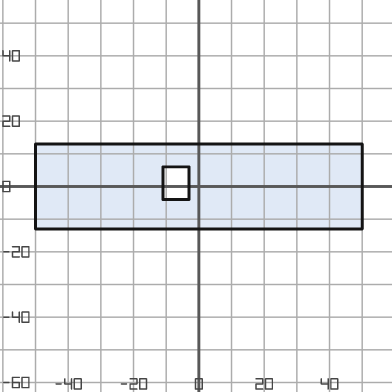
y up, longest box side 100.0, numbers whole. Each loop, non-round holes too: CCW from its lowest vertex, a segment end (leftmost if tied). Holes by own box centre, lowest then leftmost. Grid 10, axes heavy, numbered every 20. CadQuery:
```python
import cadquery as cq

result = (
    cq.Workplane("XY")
    .moveTo(-50.0, -13.0)
    .lineTo(50.0, -13.0)
    .lineTo(50.0, 13.0)
    .lineTo(-50.0, 13.0)
    .close()
    .moveTo(-11.0, -4.0)
    .lineTo(-3.0, -4.0)
    .lineTo(-3.0, 6.0)
    .lineTo(-11.0, 6.0)
    .close()
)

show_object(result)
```